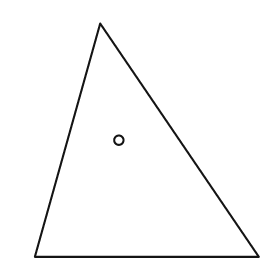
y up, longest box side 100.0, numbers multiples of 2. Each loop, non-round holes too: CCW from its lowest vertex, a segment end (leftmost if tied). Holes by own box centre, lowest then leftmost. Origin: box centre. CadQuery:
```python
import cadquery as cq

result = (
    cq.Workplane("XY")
    .moveTo(-48.0, -50.0)
    .lineTo(48.0, -50.0)
    .lineTo(-20.0, 50.0)
    .close()
    .moveTo(-12.0, 0.0)
    .circle(2.0)
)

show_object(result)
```